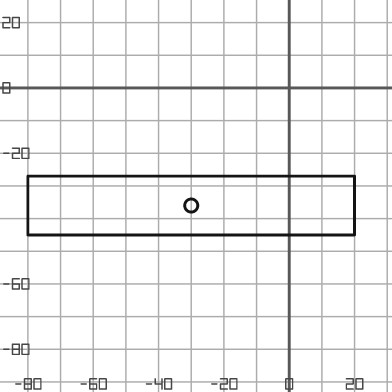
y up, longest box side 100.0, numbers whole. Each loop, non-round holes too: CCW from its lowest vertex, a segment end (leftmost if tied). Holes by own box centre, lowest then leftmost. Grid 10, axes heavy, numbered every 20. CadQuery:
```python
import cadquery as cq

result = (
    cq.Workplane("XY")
    .moveTo(-80.0, -45.0)
    .lineTo(20.0, -45.0)
    .lineTo(20.0, -27.0)
    .lineTo(-80.0, -27.0)
    .close()
    .moveTo(-30.0, -36.0)
    .circle(2.0)
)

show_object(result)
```